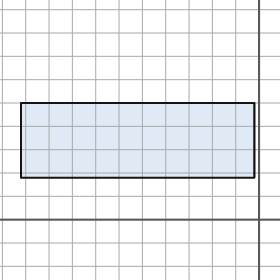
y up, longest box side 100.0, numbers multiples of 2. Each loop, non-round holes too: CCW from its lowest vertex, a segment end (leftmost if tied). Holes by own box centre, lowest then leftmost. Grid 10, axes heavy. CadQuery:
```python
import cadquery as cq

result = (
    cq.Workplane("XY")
    .moveTo(-102.0, 18.0)
    .lineTo(-2.0, 18.0)
    .lineTo(-2.0, 50.0)
    .lineTo(-102.0, 50.0)
    .close()
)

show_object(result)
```